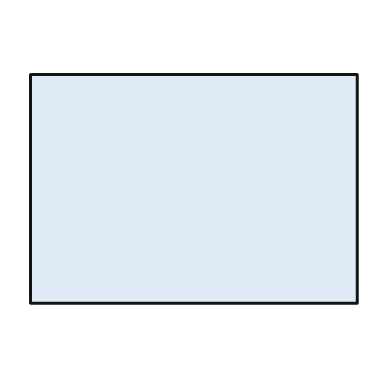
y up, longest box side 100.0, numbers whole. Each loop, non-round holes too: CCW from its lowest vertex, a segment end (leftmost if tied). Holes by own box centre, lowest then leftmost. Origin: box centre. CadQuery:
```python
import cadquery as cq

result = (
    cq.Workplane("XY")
    .moveTo(-50.0, -35.0)
    .lineTo(50.0, -35.0)
    .lineTo(50.0, 35.0)
    .lineTo(-50.0, 35.0)
    .close()
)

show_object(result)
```